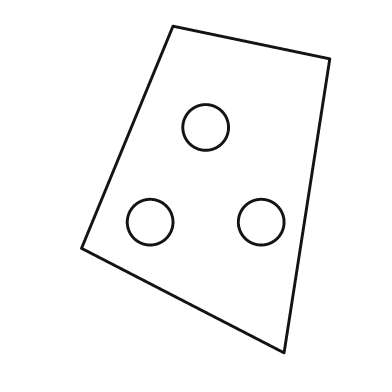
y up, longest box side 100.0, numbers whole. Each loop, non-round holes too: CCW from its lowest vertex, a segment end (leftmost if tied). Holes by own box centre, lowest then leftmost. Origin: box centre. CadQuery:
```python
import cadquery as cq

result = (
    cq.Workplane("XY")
    .moveTo(24.0, -50.0)
    .lineTo(38.0, 40.0)
    .lineTo(-10.0, 50.0)
    .lineTo(-38.0, -18.0)
    .close()
    .moveTo(-17.0, -10.0)
    .circle(7.0)
    .moveTo(17.0, -10.0)
    .circle(7.0)
    .moveTo(0.0, 19.0)
    .circle(7.0)
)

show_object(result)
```